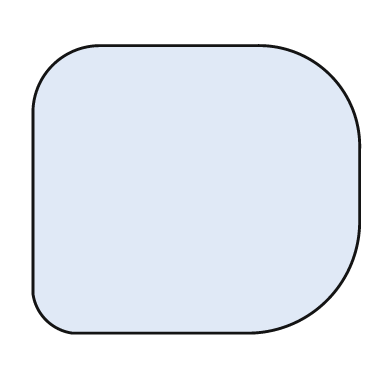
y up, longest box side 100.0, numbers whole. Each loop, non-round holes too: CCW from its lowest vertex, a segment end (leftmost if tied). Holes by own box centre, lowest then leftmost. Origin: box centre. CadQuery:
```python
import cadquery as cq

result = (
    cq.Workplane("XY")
    .moveTo(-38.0, -44.0)
    .lineTo(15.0, -44.0)
    .threePointArc((40.0, -34.0), (50.0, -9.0))
    .lineTo(50.0, 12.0)
    .threePointArc((41.0, 35.0), (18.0, 44.0))
    .lineTo(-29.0, 44.0)
    .threePointArc((-44.0, 38.0), (-50.0, 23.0))
    .lineTo(-50.0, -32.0)
    .threePointArc((-46.0, -40.0), (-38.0, -44.0))
    .close()
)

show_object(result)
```